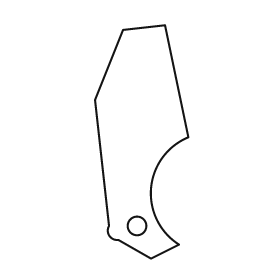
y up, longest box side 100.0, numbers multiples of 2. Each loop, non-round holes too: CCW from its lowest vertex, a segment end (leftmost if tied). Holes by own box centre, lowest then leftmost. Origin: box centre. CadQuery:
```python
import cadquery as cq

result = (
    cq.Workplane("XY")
    .moveTo(4.0, -50.0)
    .lineTo(16.0, -44.0)
    .threePointArc((4.0, -20.0), (20.0, 2.0))
    .lineTo(10.0, 50.0)
    .lineTo(-8.0, 48.0)
    .lineTo(-20.0, 18.0)
    .lineTo(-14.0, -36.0)
    .threePointArc((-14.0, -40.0), (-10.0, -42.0))
    .close()
    .moveTo(-2.0, -36.0)
    .circle(4.0)
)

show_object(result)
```